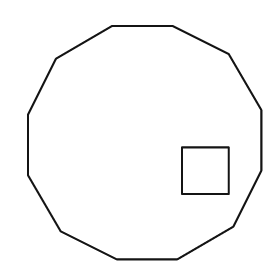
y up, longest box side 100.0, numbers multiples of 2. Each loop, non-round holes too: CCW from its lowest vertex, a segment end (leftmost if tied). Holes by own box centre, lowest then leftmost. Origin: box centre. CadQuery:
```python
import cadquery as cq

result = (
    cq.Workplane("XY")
    .moveTo(-12.0, -50.0)
    .lineTo(14.0, -50.0)
    .lineTo(38.0, -36.0)
    .lineTo(50.0, -12.0)
    .lineTo(50.0, 14.0)
    .lineTo(36.0, 38.0)
    .lineTo(12.0, 50.0)
    .lineTo(-14.0, 50.0)
    .lineTo(-38.0, 36.0)
    .lineTo(-50.0, 12.0)
    .lineTo(-50.0, -14.0)
    .lineTo(-36.0, -38.0)
    .close()
    .moveTo(16.0, -22.0)
    .lineTo(36.0, -22.0)
    .lineTo(36.0, -2.0)
    .lineTo(16.0, -2.0)
    .close()
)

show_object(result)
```